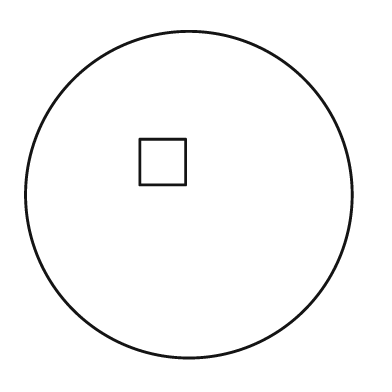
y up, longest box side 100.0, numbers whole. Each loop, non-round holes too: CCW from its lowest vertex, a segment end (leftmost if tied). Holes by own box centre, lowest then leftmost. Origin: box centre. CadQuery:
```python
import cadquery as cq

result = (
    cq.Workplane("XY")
    .moveTo(0.0, 0.0)
    .circle(50.0)
    .moveTo(-15.0, 3.0)
    .lineTo(-1.0, 3.0)
    .lineTo(-1.0, 17.0)
    .lineTo(-15.0, 17.0)
    .close()
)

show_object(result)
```